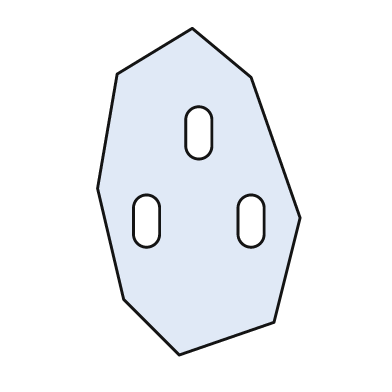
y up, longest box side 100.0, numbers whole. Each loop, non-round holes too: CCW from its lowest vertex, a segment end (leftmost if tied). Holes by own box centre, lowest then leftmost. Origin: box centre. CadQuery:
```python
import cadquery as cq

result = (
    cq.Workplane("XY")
    .moveTo(-6.0, -50.0)
    .lineTo(23.0, -40.0)
    .lineTo(31.0, -8.0)
    .lineTo(16.0, 35.0)
    .lineTo(-2.0, 50.0)
    .lineTo(-25.0, 36.0)
    .lineTo(-31.0, 1.0)
    .lineTo(-23.0, -33.0)
    .close()
    .moveTo(-20.0, -13.0)
    .threePointArc((-16.0, -17.0), (-12.0, -13.0))
    .lineTo(-12.0, -5.0)
    .threePointArc((-16.0, -1.0), (-20.0, -5.0))
    .close()
    .moveTo(12.0, -13.0)
    .threePointArc((16.0, -17.0), (20.0, -13.0))
    .lineTo(20.0, -5.0)
    .threePointArc((16.0, -1.0), (12.0, -5.0))
    .close()
    .moveTo(-4.0, 14.0)
    .threePointArc((0.0, 10.0), (4.0, 14.0))
    .lineTo(4.0, 22.0)
    .threePointArc((0.0, 26.0), (-4.0, 22.0))
    .close()
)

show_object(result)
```